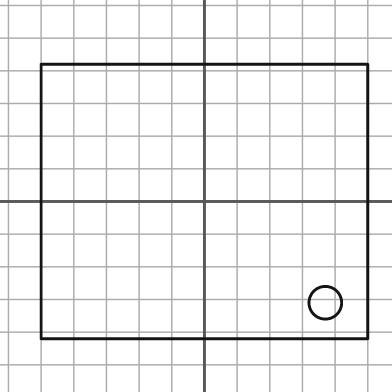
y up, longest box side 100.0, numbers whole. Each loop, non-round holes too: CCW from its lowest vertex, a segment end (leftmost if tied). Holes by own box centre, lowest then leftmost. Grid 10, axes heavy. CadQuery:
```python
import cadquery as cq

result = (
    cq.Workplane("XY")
    .moveTo(-50.0, -42.0)
    .lineTo(50.0, -42.0)
    .lineTo(50.0, 42.0)
    .lineTo(-50.0, 42.0)
    .close()
    .moveTo(37.0, -31.0)
    .circle(5.0)
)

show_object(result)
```